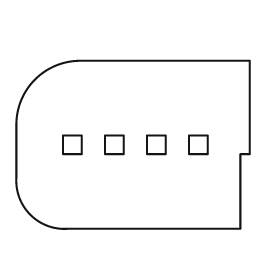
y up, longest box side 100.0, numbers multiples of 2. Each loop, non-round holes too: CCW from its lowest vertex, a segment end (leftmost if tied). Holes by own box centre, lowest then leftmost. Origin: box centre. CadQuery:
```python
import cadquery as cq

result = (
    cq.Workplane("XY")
    .moveTo(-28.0, -36.0)
    .lineTo(46.0, -36.0)
    .lineTo(46.0, -4.0)
    .lineTo(50.0, -4.0)
    .lineTo(50.0, 36.0)
    .lineTo(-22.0, 36.0)
    .threePointArc((-42.0, 28.0), (-50.0, 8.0))
    .lineTo(-50.0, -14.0)
    .threePointArc((-44.0, -30.0), (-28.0, -36.0))
    .close()
    .moveTo(-30.0, -4.0)
    .lineTo(-22.0, -4.0)
    .lineTo(-22.0, 4.0)
    .lineTo(-30.0, 4.0)
    .close()
    .moveTo(-12.0, -4.0)
    .lineTo(-4.0, -4.0)
    .lineTo(-4.0, 4.0)
    .lineTo(-12.0, 4.0)
    .close()
    .moveTo(6.0, -4.0)
    .lineTo(14.0, -4.0)
    .lineTo(14.0, 4.0)
    .lineTo(6.0, 4.0)
    .close()
    .moveTo(24.0, -4.0)
    .lineTo(32.0, -4.0)
    .lineTo(32.0, 4.0)
    .lineTo(24.0, 4.0)
    .close()
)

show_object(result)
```